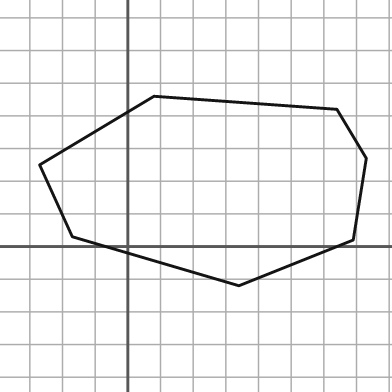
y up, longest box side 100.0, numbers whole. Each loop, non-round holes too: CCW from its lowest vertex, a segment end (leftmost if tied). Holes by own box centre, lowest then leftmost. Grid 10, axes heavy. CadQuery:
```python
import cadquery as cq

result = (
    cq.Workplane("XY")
    .moveTo(34.0, -12.0)
    .lineTo(69.0, 2.0)
    .lineTo(73.0, 27.0)
    .lineTo(64.0, 42.0)
    .lineTo(8.0, 46.0)
    .lineTo(-27.0, 25.0)
    .lineTo(-17.0, 3.0)
    .close()
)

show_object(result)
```